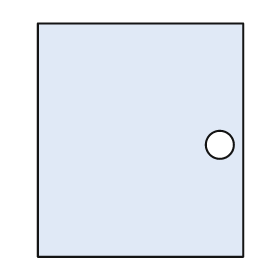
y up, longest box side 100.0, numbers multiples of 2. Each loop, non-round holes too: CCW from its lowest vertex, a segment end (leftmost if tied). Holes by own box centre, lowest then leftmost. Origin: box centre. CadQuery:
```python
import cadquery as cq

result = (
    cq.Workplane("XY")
    .moveTo(-44.0, -50.0)
    .lineTo(44.0, -50.0)
    .lineTo(44.0, 50.0)
    .lineTo(-44.0, 50.0)
    .close()
    .moveTo(34.0, -2.0)
    .circle(6.0)
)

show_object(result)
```